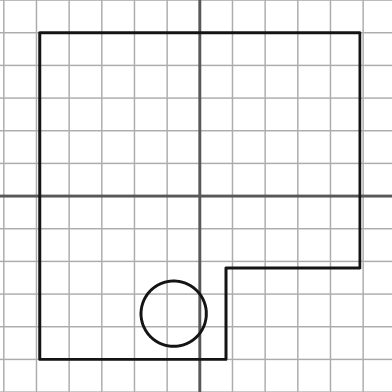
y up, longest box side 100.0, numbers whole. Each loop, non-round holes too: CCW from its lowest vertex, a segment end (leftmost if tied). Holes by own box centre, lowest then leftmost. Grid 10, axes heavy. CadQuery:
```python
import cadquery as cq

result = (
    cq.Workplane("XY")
    .moveTo(-49.0, -50.0)
    .lineTo(8.0, -50.0)
    .lineTo(8.0, -22.0)
    .lineTo(49.0, -22.0)
    .lineTo(49.0, 50.0)
    .lineTo(-49.0, 50.0)
    .close()
    .moveTo(-8.0, -36.0)
    .circle(10.0)
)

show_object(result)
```